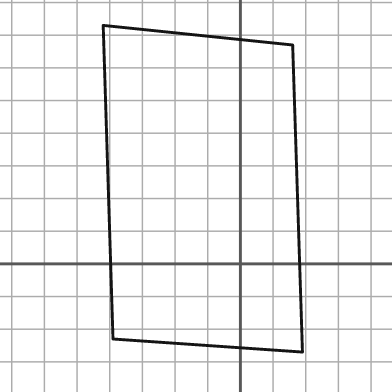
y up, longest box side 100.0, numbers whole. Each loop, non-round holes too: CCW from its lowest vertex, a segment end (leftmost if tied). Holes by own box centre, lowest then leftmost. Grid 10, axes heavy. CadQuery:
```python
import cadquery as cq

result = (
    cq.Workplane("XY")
    .moveTo(19.0, -27.0)
    .lineTo(16.0, 67.0)
    .lineTo(-42.0, 73.0)
    .lineTo(-39.0, -23.0)
    .close()
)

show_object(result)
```